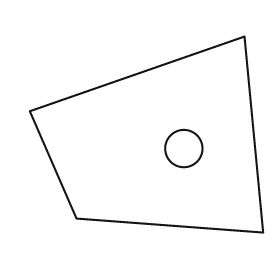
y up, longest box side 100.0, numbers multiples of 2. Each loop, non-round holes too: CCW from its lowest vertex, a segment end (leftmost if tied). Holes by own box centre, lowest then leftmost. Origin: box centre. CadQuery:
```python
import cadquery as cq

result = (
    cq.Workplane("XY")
    .moveTo(50.0, -42.0)
    .lineTo(42.0, 42.0)
    .lineTo(-50.0, 10.0)
    .lineTo(-30.0, -36.0)
    .close()
    .moveTo(16.0, -6.0)
    .circle(8.0)
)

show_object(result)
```